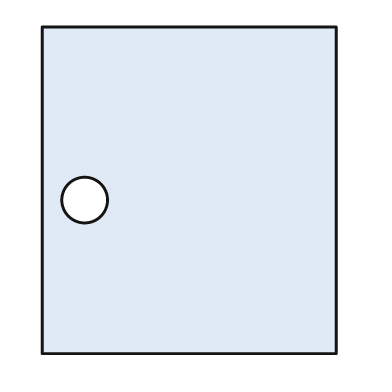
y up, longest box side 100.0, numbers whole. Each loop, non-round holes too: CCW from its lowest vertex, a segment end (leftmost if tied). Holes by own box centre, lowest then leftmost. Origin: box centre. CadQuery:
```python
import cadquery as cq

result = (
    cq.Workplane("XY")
    .moveTo(-45.0, -50.0)
    .lineTo(45.0, -50.0)
    .lineTo(45.0, 50.0)
    .lineTo(-45.0, 50.0)
    .close()
    .moveTo(-32.0, -3.0)
    .circle(7.0)
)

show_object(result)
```